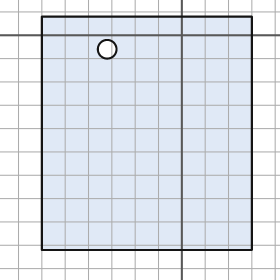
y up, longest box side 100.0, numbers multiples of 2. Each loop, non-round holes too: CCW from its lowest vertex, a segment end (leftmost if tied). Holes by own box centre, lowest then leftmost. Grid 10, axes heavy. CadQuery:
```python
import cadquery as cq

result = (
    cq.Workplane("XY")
    .moveTo(-60.0, -92.0)
    .lineTo(30.0, -92.0)
    .lineTo(30.0, 8.0)
    .lineTo(-60.0, 8.0)
    .close()
    .moveTo(-32.0, -6.0)
    .circle(4.0)
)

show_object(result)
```